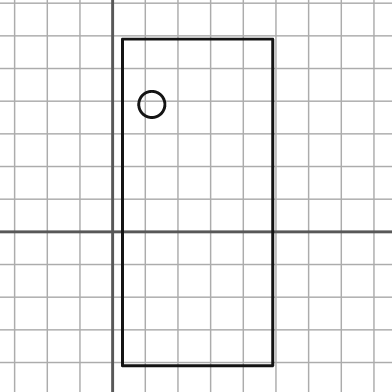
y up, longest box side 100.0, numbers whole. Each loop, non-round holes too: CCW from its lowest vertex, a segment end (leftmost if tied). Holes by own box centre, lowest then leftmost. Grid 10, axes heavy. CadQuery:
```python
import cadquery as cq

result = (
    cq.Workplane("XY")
    .moveTo(3.0, -41.0)
    .lineTo(49.0, -41.0)
    .lineTo(49.0, 59.0)
    .lineTo(3.0, 59.0)
    .close()
    .moveTo(12.0, 39.0)
    .circle(4.0)
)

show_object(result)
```